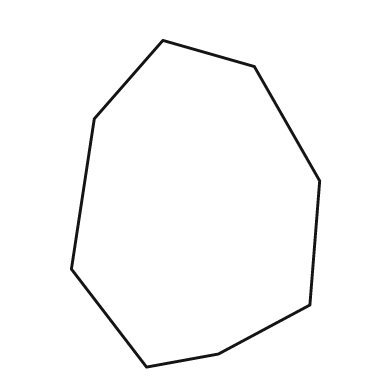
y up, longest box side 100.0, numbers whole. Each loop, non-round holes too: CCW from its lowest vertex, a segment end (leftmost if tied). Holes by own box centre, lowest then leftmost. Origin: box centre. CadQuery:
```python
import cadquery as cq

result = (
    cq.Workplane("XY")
    .moveTo(-15.0, -50.0)
    .lineTo(7.0, -46.0)
    .lineTo(35.0, -31.0)
    .lineTo(38.0, 7.0)
    .lineTo(18.0, 42.0)
    .lineTo(-10.0, 50.0)
    .lineTo(-31.0, 26.0)
    .lineTo(-38.0, -20.0)
    .close()
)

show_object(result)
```